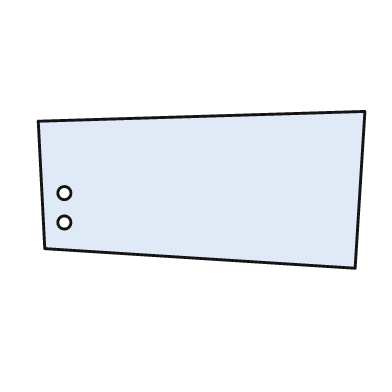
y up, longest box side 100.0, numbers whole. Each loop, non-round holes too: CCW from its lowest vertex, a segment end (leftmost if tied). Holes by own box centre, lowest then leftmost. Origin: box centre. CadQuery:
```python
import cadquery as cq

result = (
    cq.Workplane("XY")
    .moveTo(47.0, -24.0)
    .lineTo(50.0, 24.0)
    .lineTo(-50.0, 21.0)
    .lineTo(-48.0, -18.0)
    .close()
    .moveTo(-42.0, -10.0)
    .circle(2.0)
    .moveTo(-42.0, -1.0)
    .circle(2.0)
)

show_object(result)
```